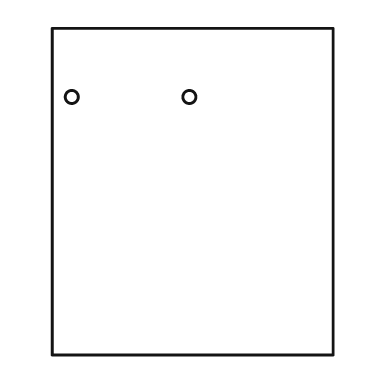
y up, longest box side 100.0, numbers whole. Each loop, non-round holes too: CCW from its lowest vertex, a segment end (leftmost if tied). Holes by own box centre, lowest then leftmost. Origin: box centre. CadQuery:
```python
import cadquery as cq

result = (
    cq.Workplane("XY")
    .moveTo(-43.0, -50.0)
    .lineTo(43.0, -50.0)
    .lineTo(43.0, 50.0)
    .lineTo(-43.0, 50.0)
    .close()
    .moveTo(-37.0, 29.0)
    .circle(2.0)
    .moveTo(-1.0, 29.0)
    .circle(2.0)
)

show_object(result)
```